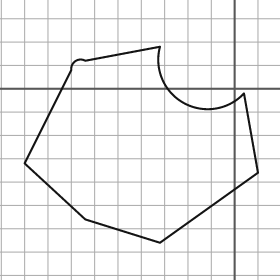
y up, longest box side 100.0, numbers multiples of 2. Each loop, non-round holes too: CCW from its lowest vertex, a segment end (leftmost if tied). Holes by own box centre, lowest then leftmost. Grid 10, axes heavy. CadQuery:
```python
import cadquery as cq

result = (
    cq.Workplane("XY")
    .moveTo(-32.0, -66.0)
    .lineTo(10.0, -36.0)
    .lineTo(4.0, -2.0)
    .threePointArc((-22.0, -6.0), (-32.0, 18.0))
    .lineTo(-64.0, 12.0)
    .threePointArc((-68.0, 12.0), (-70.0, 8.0))
    .lineTo(-90.0, -32.0)
    .lineTo(-64.0, -56.0)
    .close()
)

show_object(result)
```